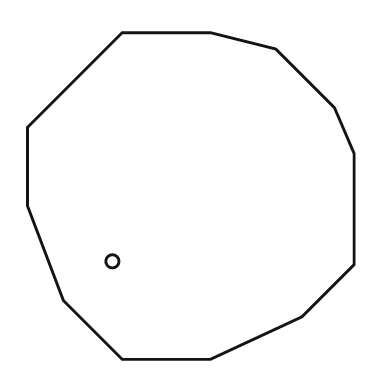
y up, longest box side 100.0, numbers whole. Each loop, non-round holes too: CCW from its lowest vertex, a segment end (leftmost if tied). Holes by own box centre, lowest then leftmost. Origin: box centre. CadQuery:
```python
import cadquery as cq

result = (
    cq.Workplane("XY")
    .moveTo(-21.0, -50.0)
    .lineTo(6.0, -50.0)
    .lineTo(34.0, -37.0)
    .lineTo(50.0, -21.0)
    .lineTo(50.0, 13.0)
    .lineTo(44.0, 27.0)
    .lineTo(26.0, 45.0)
    .lineTo(6.0, 50.0)
    .lineTo(-21.0, 50.0)
    .lineTo(-50.0, 21.0)
    .lineTo(-50.0, -3.0)
    .lineTo(-39.0, -32.0)
    .close()
    .moveTo(-24.0, -20.0)
    .circle(2.0)
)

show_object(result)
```